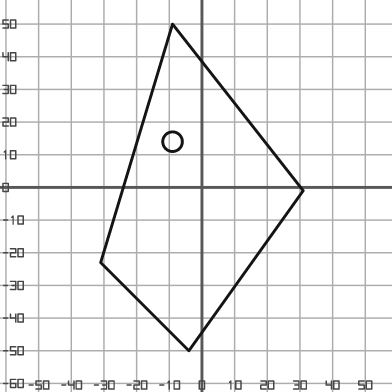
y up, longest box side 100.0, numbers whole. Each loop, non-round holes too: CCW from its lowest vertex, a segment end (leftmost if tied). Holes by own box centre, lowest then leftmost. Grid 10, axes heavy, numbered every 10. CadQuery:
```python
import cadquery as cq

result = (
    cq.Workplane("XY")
    .moveTo(-4.0, -50.0)
    .lineTo(31.0, -1.0)
    .lineTo(-9.0, 50.0)
    .lineTo(-31.0, -23.0)
    .close()
    .moveTo(-9.0, 14.0)
    .circle(3.0)
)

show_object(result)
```